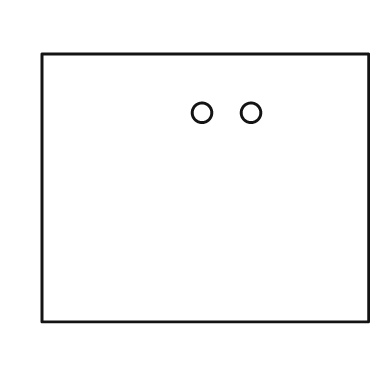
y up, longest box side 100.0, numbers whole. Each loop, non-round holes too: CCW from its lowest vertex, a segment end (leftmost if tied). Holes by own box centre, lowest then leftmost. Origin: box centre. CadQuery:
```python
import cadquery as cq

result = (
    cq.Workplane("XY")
    .moveTo(-50.0, -41.0)
    .lineTo(50.0, -41.0)
    .lineTo(50.0, 41.0)
    .lineTo(-50.0, 41.0)
    .close()
    .moveTo(-1.0, 23.0)
    .circle(3.0)
    .moveTo(14.0, 23.0)
    .circle(3.0)
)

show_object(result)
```